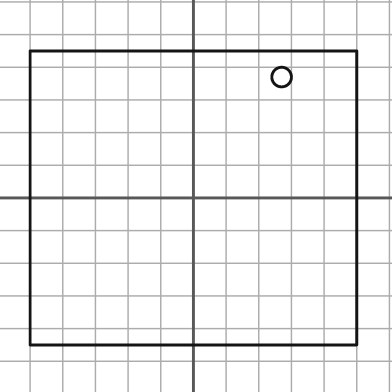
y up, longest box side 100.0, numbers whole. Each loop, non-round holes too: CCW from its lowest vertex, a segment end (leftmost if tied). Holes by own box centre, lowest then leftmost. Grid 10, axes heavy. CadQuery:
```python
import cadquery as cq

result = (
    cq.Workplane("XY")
    .moveTo(-50.0, -45.0)
    .lineTo(50.0, -45.0)
    .lineTo(50.0, 45.0)
    .lineTo(-50.0, 45.0)
    .close()
    .moveTo(27.0, 37.0)
    .circle(3.0)
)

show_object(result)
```